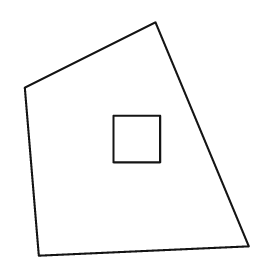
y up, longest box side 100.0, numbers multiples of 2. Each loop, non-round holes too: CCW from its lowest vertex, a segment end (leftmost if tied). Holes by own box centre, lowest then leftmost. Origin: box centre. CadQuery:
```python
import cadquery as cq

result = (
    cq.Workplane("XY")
    .moveTo(-42.0, -50.0)
    .lineTo(48.0, -46.0)
    .lineTo(8.0, 50.0)
    .lineTo(-48.0, 22.0)
    .close()
    .moveTo(-10.0, -10.0)
    .lineTo(10.0, -10.0)
    .lineTo(10.0, 10.0)
    .lineTo(-10.0, 10.0)
    .close()
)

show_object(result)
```